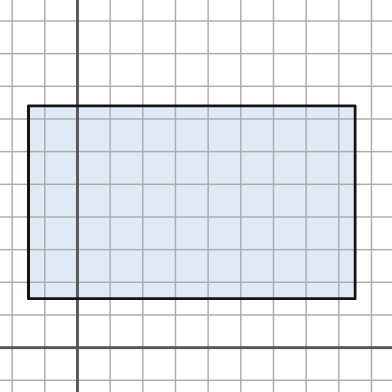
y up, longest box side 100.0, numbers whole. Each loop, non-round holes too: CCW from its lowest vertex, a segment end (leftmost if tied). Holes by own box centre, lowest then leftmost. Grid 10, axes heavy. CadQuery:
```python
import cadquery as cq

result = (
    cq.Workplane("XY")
    .moveTo(-15.0, 15.0)
    .lineTo(85.0, 15.0)
    .lineTo(85.0, 74.0)
    .lineTo(-15.0, 74.0)
    .close()
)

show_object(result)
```